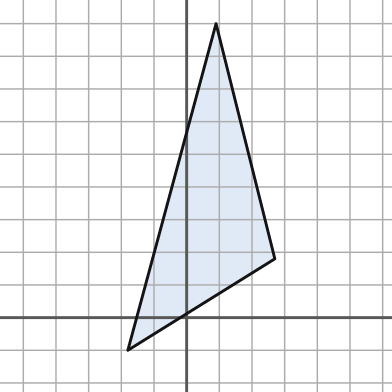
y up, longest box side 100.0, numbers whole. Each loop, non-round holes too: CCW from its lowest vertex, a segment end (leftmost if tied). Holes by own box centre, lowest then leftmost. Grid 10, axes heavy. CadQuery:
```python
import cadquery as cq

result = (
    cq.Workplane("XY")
    .moveTo(-18.0, -10.0)
    .lineTo(27.0, 18.0)
    .lineTo(9.0, 90.0)
    .close()
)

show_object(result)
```